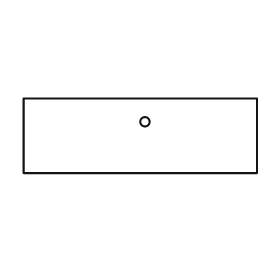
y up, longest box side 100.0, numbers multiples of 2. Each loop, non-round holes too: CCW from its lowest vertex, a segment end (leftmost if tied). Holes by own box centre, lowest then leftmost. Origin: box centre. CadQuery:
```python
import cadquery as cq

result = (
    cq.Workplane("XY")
    .moveTo(-50.0, -16.0)
    .lineTo(50.0, -16.0)
    .lineTo(50.0, 16.0)
    .lineTo(-50.0, 16.0)
    .close()
    .moveTo(2.0, 6.0)
    .circle(2.0)
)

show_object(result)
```